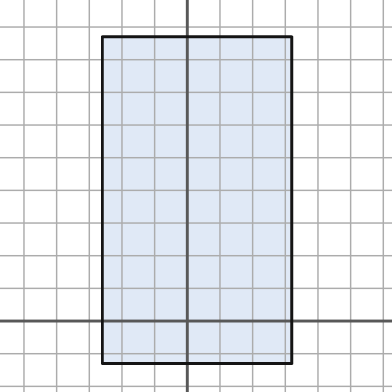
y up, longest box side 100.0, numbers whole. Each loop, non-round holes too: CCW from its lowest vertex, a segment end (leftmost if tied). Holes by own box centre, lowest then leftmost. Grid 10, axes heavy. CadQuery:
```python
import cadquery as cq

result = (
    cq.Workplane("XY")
    .moveTo(-26.0, -13.0)
    .lineTo(32.0, -13.0)
    .lineTo(32.0, 87.0)
    .lineTo(-26.0, 87.0)
    .close()
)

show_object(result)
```